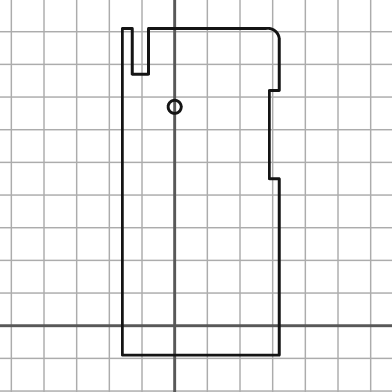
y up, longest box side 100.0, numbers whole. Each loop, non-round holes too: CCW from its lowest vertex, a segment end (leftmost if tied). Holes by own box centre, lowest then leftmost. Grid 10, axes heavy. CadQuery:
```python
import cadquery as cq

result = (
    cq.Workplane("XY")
    .moveTo(-16.0, -9.0)
    .lineTo(32.0, -9.0)
    .lineTo(32.0, 45.0)
    .lineTo(29.0, 45.0)
    .lineTo(29.0, 72.0)
    .lineTo(32.0, 72.0)
    .lineTo(32.0, 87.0)
    .threePointArc((31.0, 90.0), (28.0, 91.0))
    .lineTo(-8.0, 91.0)
    .lineTo(-8.0, 77.0)
    .lineTo(-13.0, 77.0)
    .lineTo(-13.0, 91.0)
    .lineTo(-16.0, 91.0)
    .close()
    .moveTo(0.0, 67.0)
    .circle(2.0)
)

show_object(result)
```